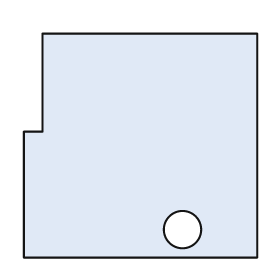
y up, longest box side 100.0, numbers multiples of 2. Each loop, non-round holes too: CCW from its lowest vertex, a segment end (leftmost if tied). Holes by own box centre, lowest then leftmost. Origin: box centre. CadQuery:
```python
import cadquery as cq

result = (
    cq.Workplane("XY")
    .moveTo(-50.0, -48.0)
    .lineTo(50.0, -48.0)
    .lineTo(50.0, 48.0)
    .lineTo(-42.0, 48.0)
    .lineTo(-42.0, 6.0)
    .lineTo(-50.0, 6.0)
    .close()
    .moveTo(18.0, -36.0)
    .circle(8.0)
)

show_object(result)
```